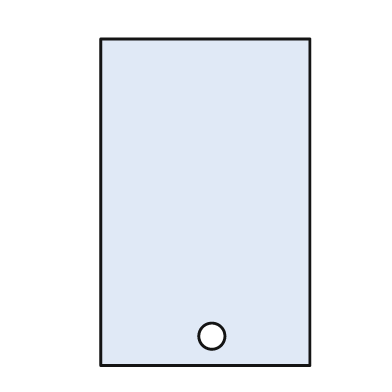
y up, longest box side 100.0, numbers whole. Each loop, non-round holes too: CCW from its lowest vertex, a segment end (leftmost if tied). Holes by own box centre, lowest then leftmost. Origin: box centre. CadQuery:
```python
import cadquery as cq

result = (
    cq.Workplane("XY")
    .moveTo(-32.0, -50.0)
    .lineTo(32.0, -50.0)
    .lineTo(32.0, 50.0)
    .lineTo(-32.0, 50.0)
    .close()
    .moveTo(2.0, -41.0)
    .circle(4.0)
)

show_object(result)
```